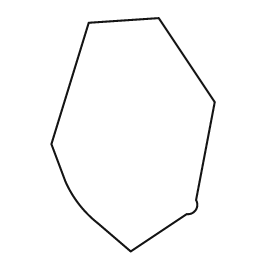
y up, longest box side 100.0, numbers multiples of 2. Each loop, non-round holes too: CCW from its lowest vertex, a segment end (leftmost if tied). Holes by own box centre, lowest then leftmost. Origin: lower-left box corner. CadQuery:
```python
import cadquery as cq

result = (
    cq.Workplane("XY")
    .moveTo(34.0, 0.0)
    .lineTo(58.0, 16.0)
    .threePointArc((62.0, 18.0), (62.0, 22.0))
    .lineTo(70.0, 64.0)
    .lineTo(46.0, 100.0)
    .lineTo(16.0, 98.0)
    .lineTo(0.0, 46.0)
    .lineTo(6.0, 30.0)
    .threePointArc((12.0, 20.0), (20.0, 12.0))
    .close()
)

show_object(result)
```